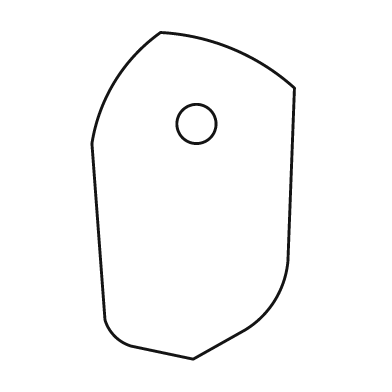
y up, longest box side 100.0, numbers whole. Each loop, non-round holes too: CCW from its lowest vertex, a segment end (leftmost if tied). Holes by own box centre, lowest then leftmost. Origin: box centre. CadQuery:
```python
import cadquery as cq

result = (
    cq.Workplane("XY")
    .moveTo(0.0, -50.0)
    .lineTo(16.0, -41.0)
    .threePointArc((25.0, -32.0), (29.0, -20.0))
    .lineTo(31.0, 33.0)
    .threePointArc((12.0, 45.0), (-10.0, 50.0))
    .threePointArc((-24.0, 35.0), (-31.0, 16.0))
    .lineTo(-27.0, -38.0)
    .threePointArc((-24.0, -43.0), (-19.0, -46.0))
    .close()
    .moveTo(1.0, 22.0)
    .circle(6.0)
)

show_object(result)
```